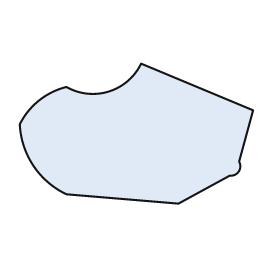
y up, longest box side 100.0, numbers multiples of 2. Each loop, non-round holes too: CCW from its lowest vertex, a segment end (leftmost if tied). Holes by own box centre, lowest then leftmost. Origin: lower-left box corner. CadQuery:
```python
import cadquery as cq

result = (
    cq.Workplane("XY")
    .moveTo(68.0, 0.0)
    .lineTo(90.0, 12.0)
    .threePointArc((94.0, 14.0), (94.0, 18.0))
    .lineTo(100.0, 40.0)
    .lineTo(52.0, 60.0)
    .threePointArc((38.0, 48.0), (20.0, 50.0))
    .threePointArc((8.0, 44.0), (0.0, 34.0))
    .threePointArc((6.0, 16.0), (20.0, 4.0))
    .close()
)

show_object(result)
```